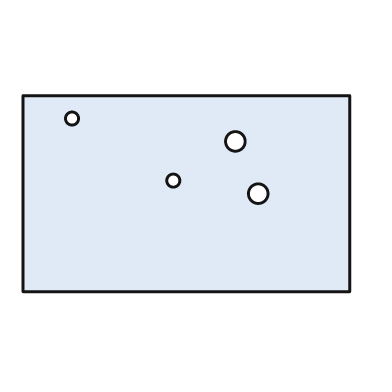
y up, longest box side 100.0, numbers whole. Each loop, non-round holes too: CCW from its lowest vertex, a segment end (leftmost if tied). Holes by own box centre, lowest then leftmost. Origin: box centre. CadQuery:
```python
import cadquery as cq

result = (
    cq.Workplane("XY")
    .moveTo(-50.0, -30.0)
    .lineTo(50.0, -30.0)
    .lineTo(50.0, 30.0)
    .lineTo(-50.0, 30.0)
    .close()
    .moveTo(22.0, 0.0)
    .circle(3.0)
    .moveTo(-4.0, 4.0)
    .circle(2.0)
    .moveTo(15.0, 16.0)
    .circle(3.0)
    .moveTo(-35.0, 23.0)
    .circle(2.0)
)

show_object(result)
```